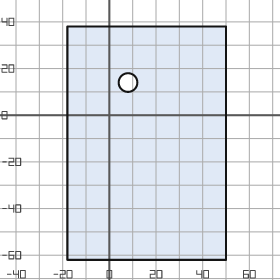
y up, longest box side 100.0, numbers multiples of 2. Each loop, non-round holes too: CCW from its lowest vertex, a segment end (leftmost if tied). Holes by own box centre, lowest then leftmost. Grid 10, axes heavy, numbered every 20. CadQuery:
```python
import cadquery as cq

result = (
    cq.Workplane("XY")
    .moveTo(-18.0, -62.0)
    .lineTo(50.0, -62.0)
    .lineTo(50.0, 38.0)
    .lineTo(-18.0, 38.0)
    .close()
    .moveTo(8.0, 14.0)
    .circle(4.0)
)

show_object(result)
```